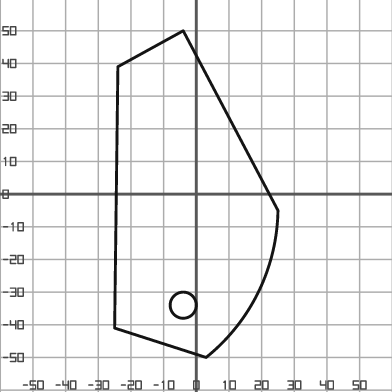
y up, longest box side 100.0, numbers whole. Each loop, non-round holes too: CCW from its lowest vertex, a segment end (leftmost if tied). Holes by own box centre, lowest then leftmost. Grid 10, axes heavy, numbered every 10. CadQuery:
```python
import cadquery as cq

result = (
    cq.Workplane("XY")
    .moveTo(3.0, -50.0)
    .threePointArc((19.0, -30.0), (25.0, -5.0))
    .lineTo(-4.0, 50.0)
    .lineTo(-24.0, 39.0)
    .lineTo(-25.0, -41.0)
    .close()
    .moveTo(-4.0, -34.0)
    .circle(4.0)
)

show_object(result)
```